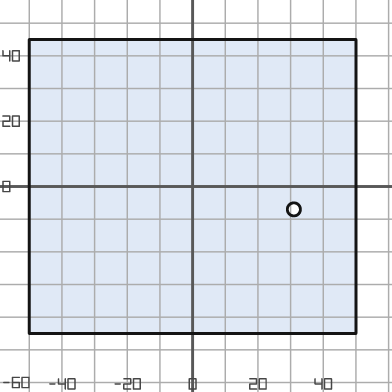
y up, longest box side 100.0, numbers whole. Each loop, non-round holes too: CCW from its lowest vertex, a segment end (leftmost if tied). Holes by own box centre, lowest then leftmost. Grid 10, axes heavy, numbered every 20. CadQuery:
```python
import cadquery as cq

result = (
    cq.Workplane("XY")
    .moveTo(-50.0, -45.0)
    .lineTo(50.0, -45.0)
    .lineTo(50.0, 45.0)
    .lineTo(-50.0, 45.0)
    .close()
    .moveTo(31.0, -7.0)
    .circle(2.0)
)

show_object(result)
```